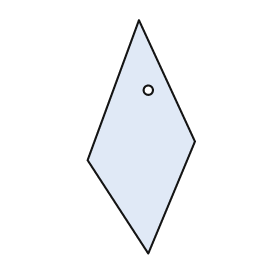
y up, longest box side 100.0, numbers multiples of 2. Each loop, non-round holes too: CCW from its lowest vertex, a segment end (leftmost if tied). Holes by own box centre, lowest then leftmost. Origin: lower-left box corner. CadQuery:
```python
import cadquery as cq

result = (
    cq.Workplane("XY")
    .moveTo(26.0, 0.0)
    .lineTo(46.0, 48.0)
    .lineTo(22.0, 100.0)
    .lineTo(0.0, 40.0)
    .close()
    .moveTo(26.0, 70.0)
    .circle(2.0)
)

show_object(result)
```